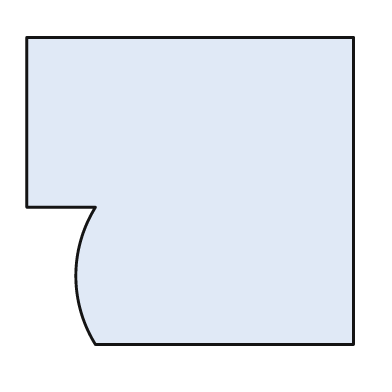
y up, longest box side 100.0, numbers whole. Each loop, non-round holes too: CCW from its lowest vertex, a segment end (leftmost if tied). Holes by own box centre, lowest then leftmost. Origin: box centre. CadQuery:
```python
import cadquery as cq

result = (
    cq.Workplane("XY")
    .moveTo(-29.0, -47.0)
    .lineTo(50.0, -47.0)
    .lineTo(50.0, 47.0)
    .lineTo(-50.0, 47.0)
    .lineTo(-50.0, -5.0)
    .lineTo(-29.0, -5.0)
    .threePointArc((-35.0, -26.0), (-29.0, -47.0))
    .close()
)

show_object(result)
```